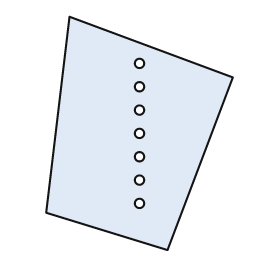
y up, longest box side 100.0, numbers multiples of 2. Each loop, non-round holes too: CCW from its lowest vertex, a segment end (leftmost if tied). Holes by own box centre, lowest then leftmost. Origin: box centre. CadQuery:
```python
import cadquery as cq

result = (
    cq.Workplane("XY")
    .moveTo(12.0, -50.0)
    .lineTo(40.0, 24.0)
    .lineTo(-30.0, 50.0)
    .lineTo(-40.0, -34.0)
    .close()
    .moveTo(0.0, -30.0)
    .circle(2.0)
    .moveTo(0.0, -20.0)
    .circle(2.0)
    .moveTo(0.0, -10.0)
    .circle(2.0)
    .moveTo(0.0, 0.0)
    .circle(2.0)
    .moveTo(0.0, 10.0)
    .circle(2.0)
    .moveTo(0.0, 20.0)
    .circle(2.0)
    .moveTo(0.0, 30.0)
    .circle(2.0)
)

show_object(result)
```